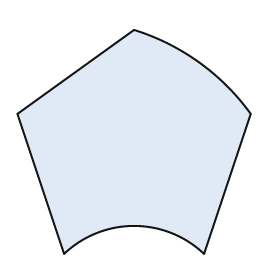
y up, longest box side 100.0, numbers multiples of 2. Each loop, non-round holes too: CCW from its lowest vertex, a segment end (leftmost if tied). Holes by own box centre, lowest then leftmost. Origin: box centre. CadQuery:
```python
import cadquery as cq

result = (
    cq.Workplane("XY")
    .moveTo(-30.0, -48.0)
    .threePointArc((0.0, -36.0), (30.0, -48.0))
    .lineTo(50.0, 12.0)
    .threePointArc((28.0, 34.0), (0.0, 48.0))
    .lineTo(-50.0, 12.0)
    .close()
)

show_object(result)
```